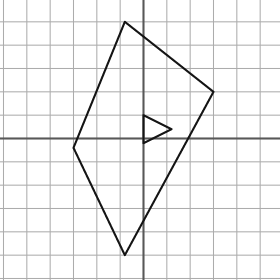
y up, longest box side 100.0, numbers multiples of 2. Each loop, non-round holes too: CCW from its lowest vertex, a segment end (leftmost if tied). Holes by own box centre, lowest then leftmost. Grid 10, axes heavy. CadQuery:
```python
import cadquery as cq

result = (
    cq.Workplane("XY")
    .moveTo(-8.0, -50.0)
    .lineTo(30.0, 20.0)
    .lineTo(-8.0, 50.0)
    .lineTo(-30.0, -4.0)
    .close()
    .moveTo(0.0, -2.0)
    .lineTo(12.0, 4.0)
    .lineTo(0.0, 10.0)
    .close()
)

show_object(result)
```